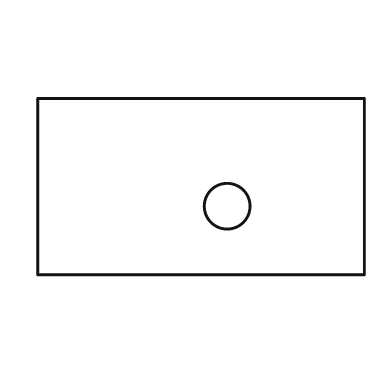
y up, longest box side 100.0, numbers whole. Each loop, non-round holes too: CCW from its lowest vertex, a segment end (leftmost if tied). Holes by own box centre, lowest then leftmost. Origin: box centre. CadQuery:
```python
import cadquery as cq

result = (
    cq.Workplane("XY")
    .moveTo(-50.0, -27.0)
    .lineTo(50.0, -27.0)
    .lineTo(50.0, 27.0)
    .lineTo(-50.0, 27.0)
    .close()
    .moveTo(8.0, -6.0)
    .circle(7.0)
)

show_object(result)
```